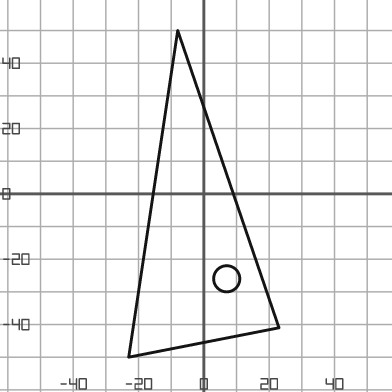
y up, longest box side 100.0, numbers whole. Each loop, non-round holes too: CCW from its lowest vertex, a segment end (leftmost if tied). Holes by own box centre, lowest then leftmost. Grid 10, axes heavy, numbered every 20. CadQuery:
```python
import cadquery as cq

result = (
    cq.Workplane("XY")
    .moveTo(-23.0, -50.0)
    .lineTo(23.0, -41.0)
    .lineTo(-8.0, 50.0)
    .close()
    .moveTo(7.0, -26.0)
    .circle(4.0)
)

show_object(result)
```